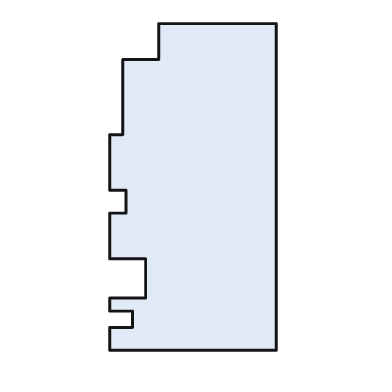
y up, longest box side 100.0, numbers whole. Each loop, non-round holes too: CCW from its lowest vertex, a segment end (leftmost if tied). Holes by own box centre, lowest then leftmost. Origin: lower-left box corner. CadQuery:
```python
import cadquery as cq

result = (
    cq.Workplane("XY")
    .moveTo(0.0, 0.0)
    .lineTo(51.0, 0.0)
    .lineTo(51.0, 100.0)
    .lineTo(15.0, 100.0)
    .lineTo(15.0, 89.0)
    .lineTo(4.0, 89.0)
    .lineTo(4.0, 66.0)
    .lineTo(0.0, 66.0)
    .lineTo(0.0, 49.0)
    .lineTo(5.0, 49.0)
    .lineTo(5.0, 42.0)
    .lineTo(0.0, 42.0)
    .lineTo(0.0, 28.0)
    .lineTo(11.0, 28.0)
    .lineTo(11.0, 16.0)
    .lineTo(0.0, 16.0)
    .lineTo(0.0, 12.0)
    .lineTo(7.0, 12.0)
    .lineTo(7.0, 7.0)
    .lineTo(0.0, 7.0)
    .close()
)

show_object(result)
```